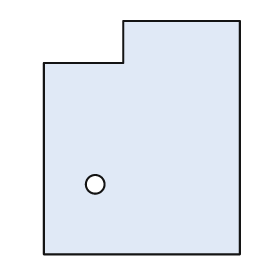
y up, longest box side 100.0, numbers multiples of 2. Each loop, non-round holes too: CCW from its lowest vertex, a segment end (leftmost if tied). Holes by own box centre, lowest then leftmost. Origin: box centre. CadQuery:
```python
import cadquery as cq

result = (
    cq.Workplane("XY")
    .moveTo(-42.0, -50.0)
    .lineTo(42.0, -50.0)
    .lineTo(42.0, 50.0)
    .lineTo(-8.0, 50.0)
    .lineTo(-8.0, 32.0)
    .lineTo(-42.0, 32.0)
    .close()
    .moveTo(-20.0, -20.0)
    .circle(4.0)
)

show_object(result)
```